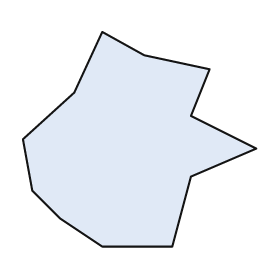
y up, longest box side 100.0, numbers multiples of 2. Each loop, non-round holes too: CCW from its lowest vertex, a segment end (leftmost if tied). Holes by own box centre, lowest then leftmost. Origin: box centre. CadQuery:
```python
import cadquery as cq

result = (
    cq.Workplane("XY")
    .moveTo(-16.0, -46.0)
    .lineTo(14.0, -46.0)
    .lineTo(22.0, -16.0)
    .lineTo(50.0, -4.0)
    .lineTo(22.0, 10.0)
    .lineTo(30.0, 30.0)
    .lineTo(2.0, 36.0)
    .lineTo(-16.0, 46.0)
    .lineTo(-28.0, 20.0)
    .lineTo(-50.0, 0.0)
    .lineTo(-46.0, -22.0)
    .lineTo(-34.0, -34.0)
    .close()
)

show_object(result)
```